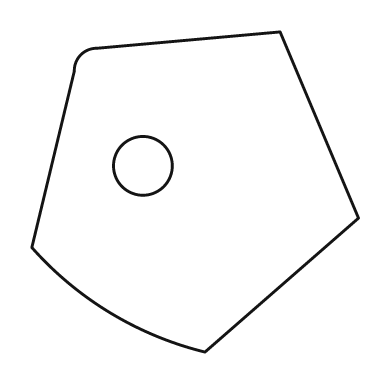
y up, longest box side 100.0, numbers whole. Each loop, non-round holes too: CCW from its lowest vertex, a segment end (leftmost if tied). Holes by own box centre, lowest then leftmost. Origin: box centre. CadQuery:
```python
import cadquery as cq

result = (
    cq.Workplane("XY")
    .moveTo(3.0, -49.0)
    .lineTo(50.0, -8.0)
    .lineTo(26.0, 49.0)
    .lineTo(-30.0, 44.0)
    .threePointArc((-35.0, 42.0), (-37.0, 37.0))
    .lineTo(-50.0, -17.0)
    .threePointArc((-26.0, -37.0), (3.0, -49.0))
    .close()
    .moveTo(-16.0, 8.0)
    .circle(9.0)
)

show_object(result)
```